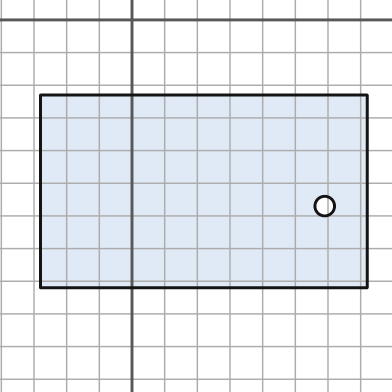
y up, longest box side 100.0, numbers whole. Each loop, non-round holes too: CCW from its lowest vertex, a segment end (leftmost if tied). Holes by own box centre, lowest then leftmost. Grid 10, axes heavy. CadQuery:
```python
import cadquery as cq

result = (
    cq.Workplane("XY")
    .moveTo(-28.0, -82.0)
    .lineTo(72.0, -82.0)
    .lineTo(72.0, -23.0)
    .lineTo(-28.0, -23.0)
    .close()
    .moveTo(59.0, -57.0)
    .circle(3.0)
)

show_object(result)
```